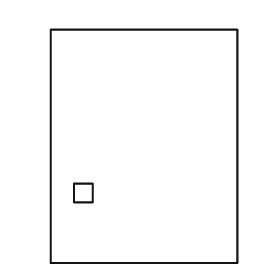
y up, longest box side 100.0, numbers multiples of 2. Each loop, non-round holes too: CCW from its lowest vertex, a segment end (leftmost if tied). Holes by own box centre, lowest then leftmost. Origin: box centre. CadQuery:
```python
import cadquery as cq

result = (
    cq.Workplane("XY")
    .moveTo(-40.0, -50.0)
    .lineTo(40.0, -50.0)
    .lineTo(40.0, 50.0)
    .lineTo(-40.0, 50.0)
    .close()
    .moveTo(-30.0, -24.0)
    .lineTo(-22.0, -24.0)
    .lineTo(-22.0, -16.0)
    .lineTo(-30.0, -16.0)
    .close()
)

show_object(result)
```